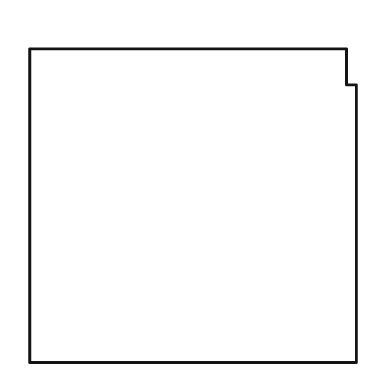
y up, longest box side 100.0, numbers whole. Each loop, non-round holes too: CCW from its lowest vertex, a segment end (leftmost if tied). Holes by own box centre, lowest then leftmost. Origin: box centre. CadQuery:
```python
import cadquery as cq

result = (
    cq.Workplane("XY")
    .moveTo(-50.0, -48.0)
    .lineTo(50.0, -48.0)
    .lineTo(50.0, 37.0)
    .lineTo(47.0, 37.0)
    .lineTo(47.0, 48.0)
    .lineTo(-50.0, 48.0)
    .close()
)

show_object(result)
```